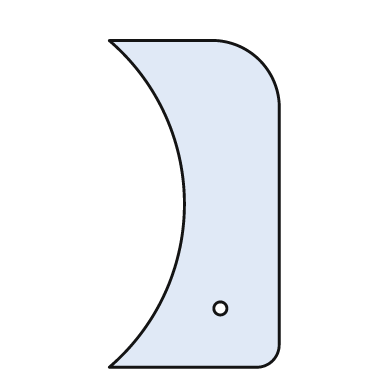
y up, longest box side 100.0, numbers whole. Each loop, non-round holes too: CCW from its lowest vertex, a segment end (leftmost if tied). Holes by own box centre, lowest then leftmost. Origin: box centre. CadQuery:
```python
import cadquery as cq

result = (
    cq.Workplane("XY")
    .moveTo(-26.0, -50.0)
    .lineTo(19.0, -50.0)
    .threePointArc((24.0, -48.0), (26.0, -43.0))
    .lineTo(26.0, 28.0)
    .threePointArc((20.0, 44.0), (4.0, 50.0))
    .lineTo(-26.0, 50.0)
    .threePointArc((-3.0, 0.0), (-26.0, -50.0))
    .close()
    .moveTo(8.0, -32.0)
    .circle(2.0)
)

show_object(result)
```